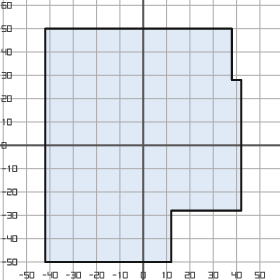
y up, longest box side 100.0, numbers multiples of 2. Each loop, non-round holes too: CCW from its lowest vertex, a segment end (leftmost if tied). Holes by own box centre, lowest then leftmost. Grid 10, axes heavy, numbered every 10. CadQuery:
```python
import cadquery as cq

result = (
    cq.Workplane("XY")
    .moveTo(-42.0, -50.0)
    .lineTo(12.0, -50.0)
    .lineTo(12.0, -28.0)
    .lineTo(42.0, -28.0)
    .lineTo(42.0, 28.0)
    .lineTo(38.0, 28.0)
    .lineTo(38.0, 50.0)
    .lineTo(-42.0, 50.0)
    .close()
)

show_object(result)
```